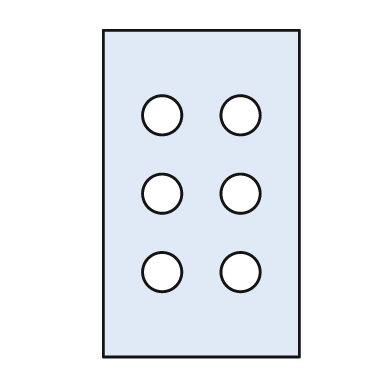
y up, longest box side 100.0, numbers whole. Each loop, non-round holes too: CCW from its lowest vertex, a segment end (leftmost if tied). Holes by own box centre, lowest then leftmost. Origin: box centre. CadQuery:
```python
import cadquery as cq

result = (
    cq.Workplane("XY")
    .moveTo(-30.0, -50.0)
    .lineTo(30.0, -50.0)
    .lineTo(30.0, 50.0)
    .lineTo(-30.0, 50.0)
    .close()
    .moveTo(-12.0, -24.0)
    .circle(6.0)
    .moveTo(12.0, -24.0)
    .circle(6.0)
    .moveTo(-12.0, 0.0)
    .circle(6.0)
    .moveTo(12.0, 0.0)
    .circle(6.0)
    .moveTo(-12.0, 24.0)
    .circle(6.0)
    .moveTo(12.0, 24.0)
    .circle(6.0)
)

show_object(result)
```